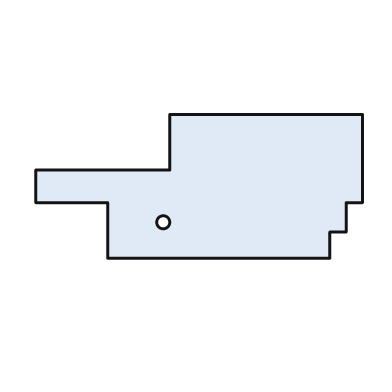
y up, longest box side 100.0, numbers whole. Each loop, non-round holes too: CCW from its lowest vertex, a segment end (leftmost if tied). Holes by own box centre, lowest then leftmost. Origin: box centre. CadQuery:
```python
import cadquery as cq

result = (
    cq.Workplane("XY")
    .moveTo(-28.0, -22.0)
    .lineTo(40.0, -22.0)
    .lineTo(40.0, -14.0)
    .lineTo(45.0, -14.0)
    .lineTo(45.0, -5.0)
    .lineTo(50.0, -5.0)
    .lineTo(50.0, 22.0)
    .lineTo(-9.0, 22.0)
    .lineTo(-9.0, 5.0)
    .lineTo(-50.0, 5.0)
    .lineTo(-50.0, -5.0)
    .lineTo(-28.0, -5.0)
    .close()
    .moveTo(-11.0, -11.0)
    .circle(2.0)
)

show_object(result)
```